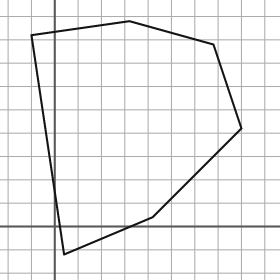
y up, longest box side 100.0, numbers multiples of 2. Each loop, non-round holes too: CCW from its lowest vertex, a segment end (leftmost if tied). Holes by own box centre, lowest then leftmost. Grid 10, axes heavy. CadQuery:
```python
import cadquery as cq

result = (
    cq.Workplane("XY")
    .moveTo(4.0, -12.0)
    .lineTo(42.0, 4.0)
    .lineTo(80.0, 42.0)
    .lineTo(68.0, 78.0)
    .lineTo(32.0, 88.0)
    .lineTo(-10.0, 82.0)
    .close()
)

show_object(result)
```